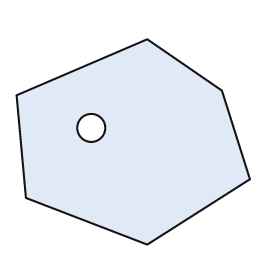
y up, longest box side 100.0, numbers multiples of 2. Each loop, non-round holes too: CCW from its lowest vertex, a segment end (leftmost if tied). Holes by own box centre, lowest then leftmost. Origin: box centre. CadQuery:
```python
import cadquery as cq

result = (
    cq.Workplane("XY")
    .moveTo(6.0, -44.0)
    .lineTo(50.0, -16.0)
    .lineTo(38.0, 22.0)
    .lineTo(6.0, 44.0)
    .lineTo(-50.0, 20.0)
    .lineTo(-46.0, -24.0)
    .close()
    .moveTo(-18.0, 6.0)
    .circle(6.0)
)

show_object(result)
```